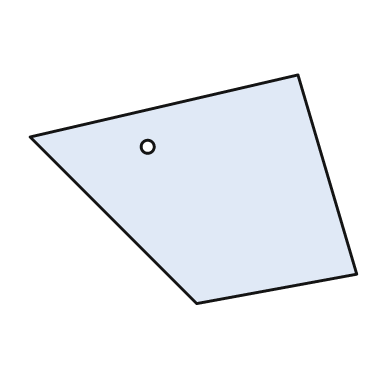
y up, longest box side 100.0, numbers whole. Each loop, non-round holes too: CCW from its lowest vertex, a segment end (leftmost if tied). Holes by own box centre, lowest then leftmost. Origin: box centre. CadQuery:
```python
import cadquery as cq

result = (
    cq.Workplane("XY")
    .moveTo(1.0, -35.0)
    .lineTo(50.0, -26.0)
    .lineTo(32.0, 35.0)
    .lineTo(-50.0, 16.0)
    .close()
    .moveTo(-14.0, 13.0)
    .circle(2.0)
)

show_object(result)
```